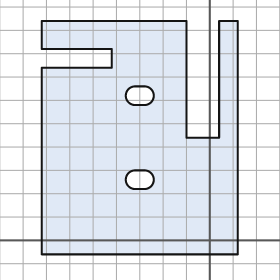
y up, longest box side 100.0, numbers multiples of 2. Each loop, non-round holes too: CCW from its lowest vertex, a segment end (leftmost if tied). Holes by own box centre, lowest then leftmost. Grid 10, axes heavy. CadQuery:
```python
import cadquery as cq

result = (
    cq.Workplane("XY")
    .moveTo(-72.0, -6.0)
    .lineTo(12.0, -6.0)
    .lineTo(12.0, 94.0)
    .lineTo(4.0, 94.0)
    .lineTo(4.0, 44.0)
    .lineTo(-10.0, 44.0)
    .lineTo(-10.0, 94.0)
    .lineTo(-72.0, 94.0)
    .lineTo(-72.0, 82.0)
    .lineTo(-42.0, 82.0)
    .lineTo(-42.0, 74.0)
    .lineTo(-72.0, 74.0)
    .close()
    .moveTo(-32.0, 22.0)
    .lineTo(-28.0, 22.0)
    .threePointArc((-24.0, 26.0), (-28.0, 30.0))
    .lineTo(-32.0, 30.0)
    .threePointArc((-36.0, 26.0), (-32.0, 22.0))
    .close()
    .moveTo(-32.0, 58.0)
    .lineTo(-28.0, 58.0)
    .threePointArc((-24.0, 62.0), (-28.0, 66.0))
    .lineTo(-32.0, 66.0)
    .threePointArc((-36.0, 62.0), (-32.0, 58.0))
    .close()
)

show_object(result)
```